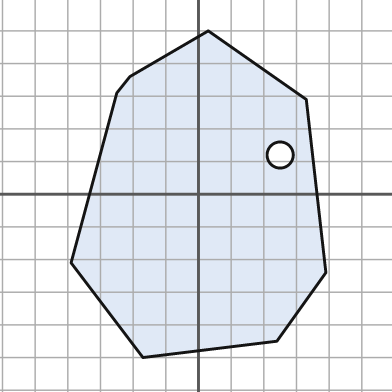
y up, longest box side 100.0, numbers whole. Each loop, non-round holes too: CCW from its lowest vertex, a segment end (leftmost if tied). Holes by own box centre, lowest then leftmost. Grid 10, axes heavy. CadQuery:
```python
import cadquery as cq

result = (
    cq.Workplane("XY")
    .moveTo(-17.0, -50.0)
    .lineTo(24.0, -45.0)
    .lineTo(39.0, -24.0)
    .lineTo(33.0, 29.0)
    .lineTo(3.0, 50.0)
    .lineTo(-21.0, 36.0)
    .lineTo(-25.0, 31.0)
    .lineTo(-39.0, -21.0)
    .close()
    .moveTo(25.0, 12.0)
    .circle(4.0)
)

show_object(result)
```